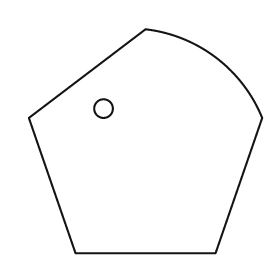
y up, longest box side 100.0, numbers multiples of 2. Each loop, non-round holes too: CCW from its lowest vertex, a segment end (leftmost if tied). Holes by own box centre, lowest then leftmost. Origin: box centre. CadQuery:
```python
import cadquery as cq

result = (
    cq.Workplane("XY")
    .moveTo(-30.0, -48.0)
    .lineTo(30.0, -48.0)
    .lineTo(50.0, 10.0)
    .threePointArc((30.0, 36.0), (0.0, 48.0))
    .lineTo(-50.0, 10.0)
    .close()
    .moveTo(-18.0, 14.0)
    .circle(4.0)
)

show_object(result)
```